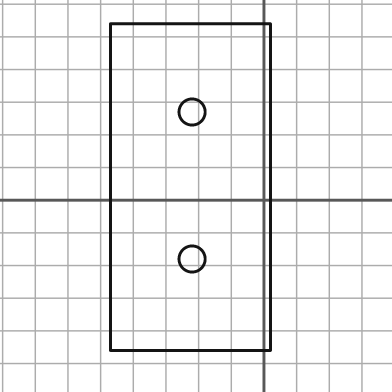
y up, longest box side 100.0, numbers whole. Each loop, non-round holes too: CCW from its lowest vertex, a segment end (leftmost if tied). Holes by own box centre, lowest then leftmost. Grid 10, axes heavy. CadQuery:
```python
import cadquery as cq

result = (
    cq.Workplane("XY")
    .moveTo(-47.0, -46.0)
    .lineTo(2.0, -46.0)
    .lineTo(2.0, 54.0)
    .lineTo(-47.0, 54.0)
    .close()
    .moveTo(-22.0, -18.0)
    .circle(4.0)
    .moveTo(-22.0, 27.0)
    .circle(4.0)
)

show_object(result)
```